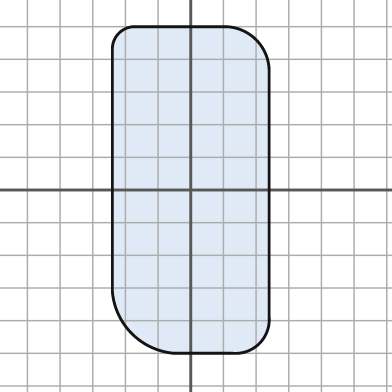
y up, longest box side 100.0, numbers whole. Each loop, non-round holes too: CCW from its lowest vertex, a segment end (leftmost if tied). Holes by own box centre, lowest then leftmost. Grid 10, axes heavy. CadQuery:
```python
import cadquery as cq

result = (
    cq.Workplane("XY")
    .moveTo(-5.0, -50.0)
    .lineTo(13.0, -50.0)
    .threePointArc((21.0, -47.0), (24.0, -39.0))
    .lineTo(24.0, 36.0)
    .threePointArc((20.0, 46.0), (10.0, 50.0))
    .lineTo(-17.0, 50.0)
    .threePointArc((-22.0, 48.0), (-24.0, 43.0))
    .lineTo(-24.0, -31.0)
    .threePointArc((-18.0, -44.0), (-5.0, -50.0))
    .close()
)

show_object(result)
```